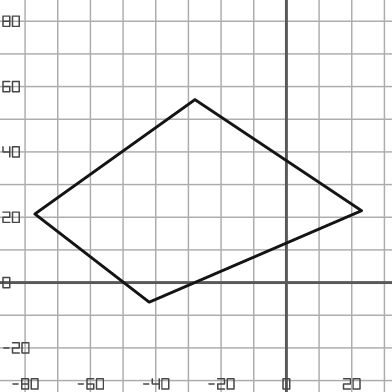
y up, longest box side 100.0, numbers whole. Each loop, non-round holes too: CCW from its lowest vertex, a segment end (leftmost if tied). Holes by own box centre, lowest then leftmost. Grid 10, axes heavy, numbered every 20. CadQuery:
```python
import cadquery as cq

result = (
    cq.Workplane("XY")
    .moveTo(-42.0, -6.0)
    .lineTo(23.0, 22.0)
    .lineTo(-28.0, 56.0)
    .lineTo(-77.0, 21.0)
    .close()
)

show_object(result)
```